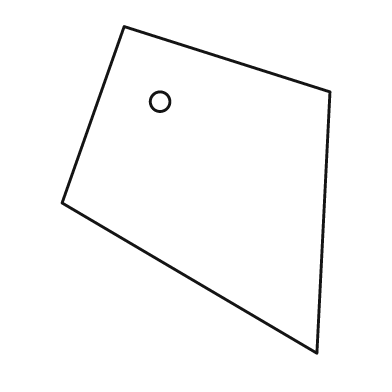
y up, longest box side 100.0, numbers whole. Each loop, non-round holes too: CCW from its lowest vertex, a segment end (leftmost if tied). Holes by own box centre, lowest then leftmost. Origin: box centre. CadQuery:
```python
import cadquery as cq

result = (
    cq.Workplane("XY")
    .moveTo(37.0, -50.0)
    .lineTo(41.0, 30.0)
    .lineTo(-22.0, 50.0)
    .lineTo(-41.0, -4.0)
    .close()
    .moveTo(-11.0, 27.0)
    .circle(3.0)
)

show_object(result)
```